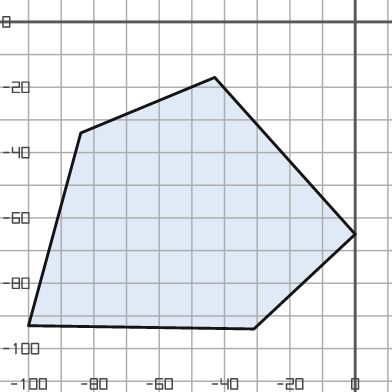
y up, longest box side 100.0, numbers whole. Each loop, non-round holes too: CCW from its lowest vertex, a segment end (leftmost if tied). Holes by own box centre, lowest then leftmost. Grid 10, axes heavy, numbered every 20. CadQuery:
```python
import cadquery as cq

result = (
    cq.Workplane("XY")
    .moveTo(-31.0, -94.0)
    .lineTo(0.0, -65.0)
    .lineTo(-43.0, -17.0)
    .lineTo(-84.0, -34.0)
    .lineTo(-100.0, -93.0)
    .close()
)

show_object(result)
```